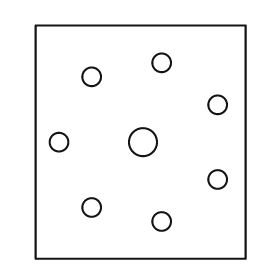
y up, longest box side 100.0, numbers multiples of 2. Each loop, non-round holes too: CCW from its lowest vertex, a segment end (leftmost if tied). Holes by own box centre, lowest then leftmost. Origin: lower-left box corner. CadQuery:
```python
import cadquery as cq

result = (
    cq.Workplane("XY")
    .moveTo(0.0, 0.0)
    .lineTo(90.0, 0.0)
    .lineTo(90.0, 100.0)
    .lineTo(0.0, 100.0)
    .close()
    .moveTo(54.0, 16.0)
    .circle(4.0)
    .moveTo(24.0, 22.0)
    .circle(4.0)
    .moveTo(78.0, 34.0)
    .circle(4.0)
    .moveTo(10.0, 50.0)
    .circle(4.0)
    .moveTo(46.0, 50.0)
    .circle(6.0)
    .moveTo(78.0, 66.0)
    .circle(4.0)
    .moveTo(24.0, 78.0)
    .circle(4.0)
    .moveTo(54.0, 84.0)
    .circle(4.0)
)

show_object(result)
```